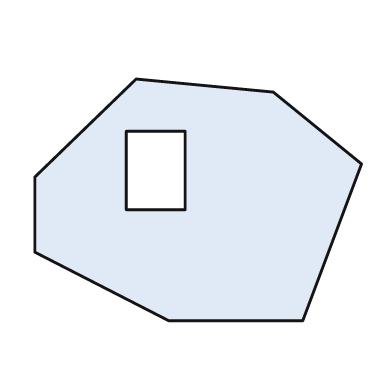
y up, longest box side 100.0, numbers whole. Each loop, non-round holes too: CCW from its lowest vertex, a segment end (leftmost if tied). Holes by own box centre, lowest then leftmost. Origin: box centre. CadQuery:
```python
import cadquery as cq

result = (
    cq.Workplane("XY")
    .moveTo(-9.0, -37.0)
    .lineTo(32.0, -37.0)
    .lineTo(50.0, 11.0)
    .lineTo(23.0, 33.0)
    .lineTo(-19.0, 37.0)
    .lineTo(-50.0, 7.0)
    .lineTo(-50.0, -16.0)
    .close()
    .moveTo(-22.0, -3.0)
    .lineTo(-4.0, -3.0)
    .lineTo(-4.0, 21.0)
    .lineTo(-22.0, 21.0)
    .close()
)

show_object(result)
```